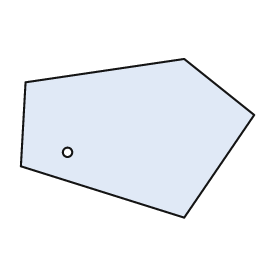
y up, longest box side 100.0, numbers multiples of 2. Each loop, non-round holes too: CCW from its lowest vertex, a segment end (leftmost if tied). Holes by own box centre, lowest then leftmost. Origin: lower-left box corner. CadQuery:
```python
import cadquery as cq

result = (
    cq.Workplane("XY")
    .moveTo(70.0, 0.0)
    .lineTo(100.0, 44.0)
    .lineTo(70.0, 68.0)
    .lineTo(2.0, 58.0)
    .lineTo(0.0, 22.0)
    .close()
    .moveTo(20.0, 28.0)
    .circle(2.0)
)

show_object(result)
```